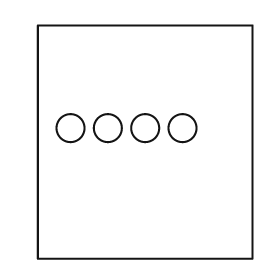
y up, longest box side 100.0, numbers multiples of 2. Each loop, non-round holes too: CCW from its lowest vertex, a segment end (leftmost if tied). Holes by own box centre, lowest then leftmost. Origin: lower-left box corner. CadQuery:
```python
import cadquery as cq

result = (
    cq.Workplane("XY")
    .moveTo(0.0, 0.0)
    .lineTo(92.0, 0.0)
    .lineTo(92.0, 100.0)
    .lineTo(0.0, 100.0)
    .close()
    .moveTo(14.0, 56.0)
    .circle(6.0)
    .moveTo(30.0, 56.0)
    .circle(6.0)
    .moveTo(46.0, 56.0)
    .circle(6.0)
    .moveTo(62.0, 56.0)
    .circle(6.0)
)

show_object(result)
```